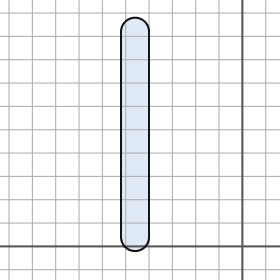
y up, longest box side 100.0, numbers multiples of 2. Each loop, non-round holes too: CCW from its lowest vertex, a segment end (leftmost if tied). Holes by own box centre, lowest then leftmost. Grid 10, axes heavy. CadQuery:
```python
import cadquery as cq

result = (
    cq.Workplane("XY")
    .moveTo(-52.0, 4.0)
    .threePointArc((-46.0, -2.0), (-40.0, 4.0))
    .lineTo(-40.0, 92.0)
    .threePointArc((-46.0, 98.0), (-52.0, 92.0))
    .close()
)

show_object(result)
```